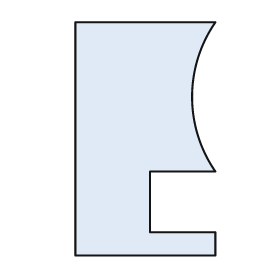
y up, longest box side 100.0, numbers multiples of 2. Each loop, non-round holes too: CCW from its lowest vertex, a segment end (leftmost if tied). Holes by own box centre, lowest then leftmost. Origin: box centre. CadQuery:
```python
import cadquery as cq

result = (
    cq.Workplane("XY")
    .moveTo(-30.0, -50.0)
    .lineTo(30.0, -50.0)
    .lineTo(30.0, -40.0)
    .lineTo(2.0, -40.0)
    .lineTo(2.0, -14.0)
    .lineTo(30.0, -14.0)
    .threePointArc((20.0, 18.0), (30.0, 50.0))
    .lineTo(-30.0, 50.0)
    .close()
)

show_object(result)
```